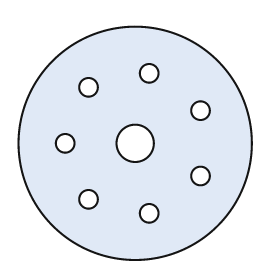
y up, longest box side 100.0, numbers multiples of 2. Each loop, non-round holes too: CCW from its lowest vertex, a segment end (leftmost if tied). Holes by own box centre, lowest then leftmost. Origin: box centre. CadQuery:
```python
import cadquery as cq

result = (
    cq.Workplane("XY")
    .moveTo(0.0, 0.0)
    .circle(50.0)
    .moveTo(6.0, -30.0)
    .circle(4.0)
    .moveTo(-20.0, -24.0)
    .circle(4.0)
    .moveTo(28.0, -14.0)
    .circle(4.0)
    .moveTo(-30.0, 0.0)
    .circle(4.0)
    .moveTo(0.0, 0.0)
    .circle(8.0)
    .moveTo(28.0, 14.0)
    .circle(4.0)
    .moveTo(-20.0, 24.0)
    .circle(4.0)
    .moveTo(6.0, 30.0)
    .circle(4.0)
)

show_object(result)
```